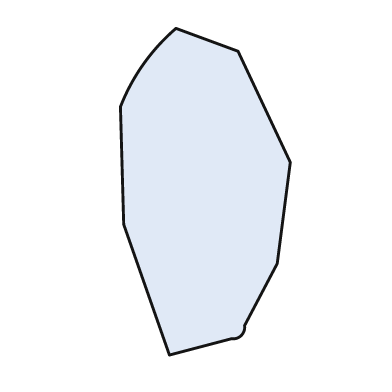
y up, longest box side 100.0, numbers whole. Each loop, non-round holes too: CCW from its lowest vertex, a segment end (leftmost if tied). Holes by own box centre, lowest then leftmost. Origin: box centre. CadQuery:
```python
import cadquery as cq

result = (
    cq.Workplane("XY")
    .moveTo(-11.0, -50.0)
    .lineTo(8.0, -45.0)
    .threePointArc((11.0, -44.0), (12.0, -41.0))
    .lineTo(22.0, -22.0)
    .lineTo(26.0, 9.0)
    .lineTo(10.0, 43.0)
    .lineTo(-9.0, 50.0)
    .threePointArc((-19.0, 39.0), (-26.0, 26.0))
    .lineTo(-25.0, -10.0)
    .close()
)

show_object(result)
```